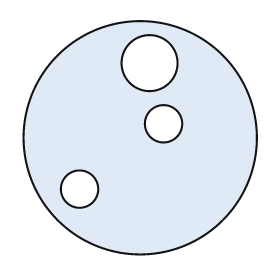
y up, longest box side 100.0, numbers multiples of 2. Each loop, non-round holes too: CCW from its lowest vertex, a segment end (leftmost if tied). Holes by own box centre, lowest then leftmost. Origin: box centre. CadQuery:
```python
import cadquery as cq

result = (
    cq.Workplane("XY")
    .moveTo(0.0, 0.0)
    .circle(50.0)
    .moveTo(-26.0, -22.0)
    .circle(8.0)
    .moveTo(10.0, 6.0)
    .circle(8.0)
    .moveTo(4.0, 32.0)
    .circle(12.0)
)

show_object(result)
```